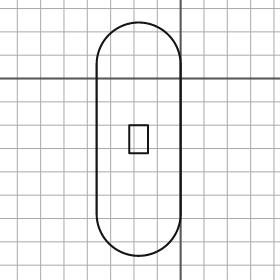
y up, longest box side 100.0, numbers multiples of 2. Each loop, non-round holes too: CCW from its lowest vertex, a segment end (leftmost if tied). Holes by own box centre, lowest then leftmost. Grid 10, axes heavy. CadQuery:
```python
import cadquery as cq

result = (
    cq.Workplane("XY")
    .moveTo(-36.0, -58.0)
    .threePointArc((-18.0, -76.0), (0.0, -58.0))
    .lineTo(0.0, 6.0)
    .threePointArc((-18.0, 24.0), (-36.0, 6.0))
    .close()
    .moveTo(-22.0, -32.0)
    .lineTo(-14.0, -32.0)
    .lineTo(-14.0, -20.0)
    .lineTo(-22.0, -20.0)
    .close()
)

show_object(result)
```